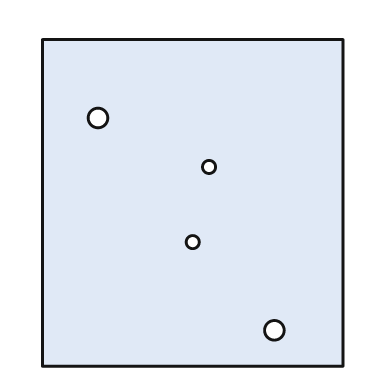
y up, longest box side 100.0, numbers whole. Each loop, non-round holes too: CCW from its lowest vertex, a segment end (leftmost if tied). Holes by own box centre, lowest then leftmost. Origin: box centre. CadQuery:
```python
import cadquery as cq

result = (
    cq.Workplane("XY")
    .moveTo(-46.0, -50.0)
    .lineTo(46.0, -50.0)
    .lineTo(46.0, 50.0)
    .lineTo(-46.0, 50.0)
    .close()
    .moveTo(25.0, -39.0)
    .circle(3.0)
    .moveTo(0.0, -12.0)
    .circle(2.0)
    .moveTo(5.0, 11.0)
    .circle(2.0)
    .moveTo(-29.0, 26.0)
    .circle(3.0)
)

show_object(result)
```